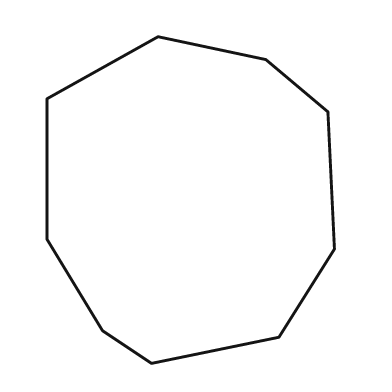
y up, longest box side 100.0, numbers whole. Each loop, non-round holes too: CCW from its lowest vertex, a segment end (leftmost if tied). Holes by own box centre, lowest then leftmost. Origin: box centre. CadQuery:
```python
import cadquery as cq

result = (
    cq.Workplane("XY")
    .moveTo(-12.0, -50.0)
    .lineTo(27.0, -42.0)
    .lineTo(44.0, -15.0)
    .lineTo(42.0, 27.0)
    .lineTo(23.0, 43.0)
    .lineTo(-10.0, 50.0)
    .lineTo(-44.0, 31.0)
    .lineTo(-44.0, -12.0)
    .lineTo(-27.0, -40.0)
    .close()
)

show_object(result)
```